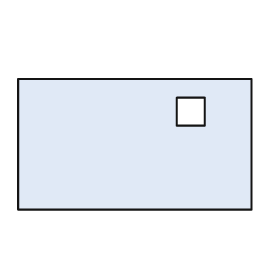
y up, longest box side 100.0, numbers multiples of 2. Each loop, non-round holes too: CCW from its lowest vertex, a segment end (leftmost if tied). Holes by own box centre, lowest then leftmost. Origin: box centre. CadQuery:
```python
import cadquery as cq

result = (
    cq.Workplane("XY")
    .moveTo(-50.0, -28.0)
    .lineTo(50.0, -28.0)
    .lineTo(50.0, 28.0)
    .lineTo(-50.0, 28.0)
    .close()
    .moveTo(18.0, 8.0)
    .lineTo(30.0, 8.0)
    .lineTo(30.0, 20.0)
    .lineTo(18.0, 20.0)
    .close()
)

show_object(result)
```